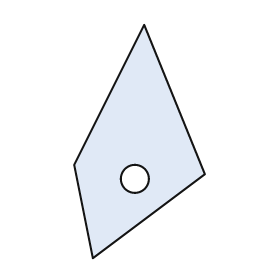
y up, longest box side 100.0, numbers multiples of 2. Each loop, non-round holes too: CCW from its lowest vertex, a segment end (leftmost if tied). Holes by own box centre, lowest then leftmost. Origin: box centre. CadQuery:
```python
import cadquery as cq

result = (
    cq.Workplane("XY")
    .moveTo(-20.0, -50.0)
    .lineTo(28.0, -14.0)
    .lineTo(2.0, 50.0)
    .lineTo(-28.0, -10.0)
    .close()
    .moveTo(-2.0, -16.0)
    .circle(6.0)
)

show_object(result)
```